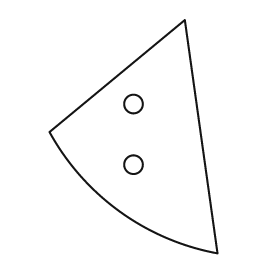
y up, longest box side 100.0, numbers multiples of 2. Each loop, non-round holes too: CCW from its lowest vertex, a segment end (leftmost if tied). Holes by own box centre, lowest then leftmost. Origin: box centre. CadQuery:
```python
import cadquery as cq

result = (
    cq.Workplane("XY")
    .moveTo(36.0, -50.0)
    .lineTo(22.0, 50.0)
    .lineTo(-36.0, 2.0)
    .threePointArc((-6.0, -32.0), (36.0, -50.0))
    .close()
    .moveTo(0.0, -12.0)
    .circle(4.0)
    .moveTo(0.0, 14.0)
    .circle(4.0)
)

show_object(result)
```